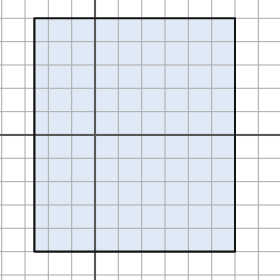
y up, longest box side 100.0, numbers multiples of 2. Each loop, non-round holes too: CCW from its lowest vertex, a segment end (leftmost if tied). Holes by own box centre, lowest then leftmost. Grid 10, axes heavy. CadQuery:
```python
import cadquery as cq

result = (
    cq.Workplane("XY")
    .moveTo(-26.0, -50.0)
    .lineTo(60.0, -50.0)
    .lineTo(60.0, 50.0)
    .lineTo(-26.0, 50.0)
    .close()
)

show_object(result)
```